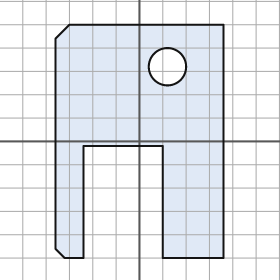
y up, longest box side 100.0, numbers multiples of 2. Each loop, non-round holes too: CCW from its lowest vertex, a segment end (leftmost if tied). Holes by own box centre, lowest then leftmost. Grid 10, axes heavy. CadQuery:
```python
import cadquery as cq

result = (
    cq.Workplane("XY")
    .moveTo(-32.0, -50.0)
    .lineTo(-24.0, -50.0)
    .lineTo(-24.0, -2.0)
    .lineTo(10.0, -2.0)
    .lineTo(10.0, -50.0)
    .lineTo(36.0, -50.0)
    .lineTo(36.0, 50.0)
    .lineTo(-30.0, 50.0)
    .lineTo(-36.0, 44.0)
    .lineTo(-36.0, -46.0)
    .close()
    .moveTo(12.0, 32.0)
    .circle(8.0)
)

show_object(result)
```